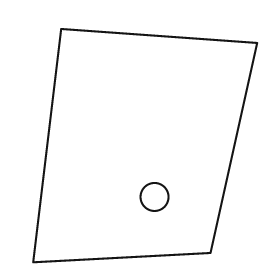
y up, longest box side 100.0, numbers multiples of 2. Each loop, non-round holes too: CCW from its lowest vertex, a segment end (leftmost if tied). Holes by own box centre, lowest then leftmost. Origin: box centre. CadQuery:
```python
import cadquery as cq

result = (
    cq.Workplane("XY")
    .moveTo(-48.0, -50.0)
    .lineTo(28.0, -46.0)
    .lineTo(48.0, 44.0)
    .lineTo(-36.0, 50.0)
    .close()
    .moveTo(4.0, -22.0)
    .circle(6.0)
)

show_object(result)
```